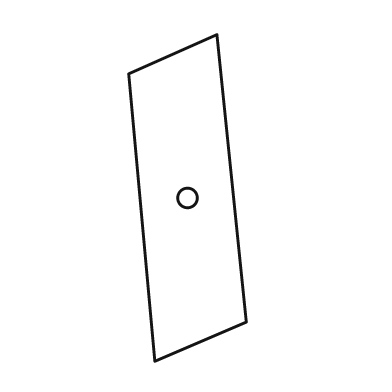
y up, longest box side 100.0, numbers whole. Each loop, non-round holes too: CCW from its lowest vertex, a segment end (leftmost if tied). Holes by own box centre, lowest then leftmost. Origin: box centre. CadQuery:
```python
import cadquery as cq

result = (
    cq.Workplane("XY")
    .moveTo(-10.0, -50.0)
    .lineTo(18.0, -38.0)
    .lineTo(9.0, 50.0)
    .lineTo(-18.0, 38.0)
    .close()
    .moveTo(0.0, 0.0)
    .circle(3.0)
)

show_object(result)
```